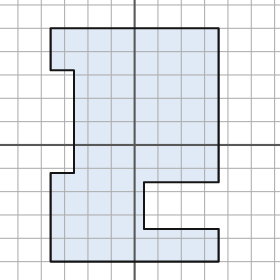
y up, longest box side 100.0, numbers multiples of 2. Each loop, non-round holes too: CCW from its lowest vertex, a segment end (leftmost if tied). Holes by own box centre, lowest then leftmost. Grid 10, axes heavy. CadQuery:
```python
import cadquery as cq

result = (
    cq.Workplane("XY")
    .moveTo(-36.0, -50.0)
    .lineTo(36.0, -50.0)
    .lineTo(36.0, -36.0)
    .lineTo(4.0, -36.0)
    .lineTo(4.0, -16.0)
    .lineTo(36.0, -16.0)
    .lineTo(36.0, 50.0)
    .lineTo(-36.0, 50.0)
    .lineTo(-36.0, 32.0)
    .lineTo(-26.0, 32.0)
    .lineTo(-26.0, -12.0)
    .lineTo(-36.0, -12.0)
    .close()
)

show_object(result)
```